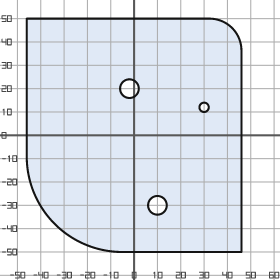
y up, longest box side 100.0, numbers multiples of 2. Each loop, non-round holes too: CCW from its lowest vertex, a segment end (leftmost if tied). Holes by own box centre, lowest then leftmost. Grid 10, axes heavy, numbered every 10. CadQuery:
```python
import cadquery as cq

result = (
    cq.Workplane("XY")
    .moveTo(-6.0, -50.0)
    .lineTo(46.0, -50.0)
    .lineTo(46.0, 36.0)
    .threePointArc((42.0, 46.0), (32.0, 50.0))
    .lineTo(-46.0, 50.0)
    .lineTo(-46.0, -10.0)
    .threePointArc((-34.0, -38.0), (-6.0, -50.0))
    .close()
    .moveTo(10.0, -30.0)
    .circle(4.0)
    .moveTo(30.0, 12.0)
    .circle(2.0)
    .moveTo(-2.0, 20.0)
    .circle(4.0)
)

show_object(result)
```